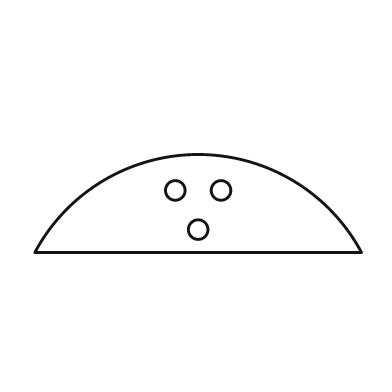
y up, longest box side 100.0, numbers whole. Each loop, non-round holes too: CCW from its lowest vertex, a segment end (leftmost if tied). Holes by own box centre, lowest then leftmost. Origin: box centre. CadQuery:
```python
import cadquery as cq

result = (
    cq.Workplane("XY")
    .moveTo(-50.0, -15.0)
    .lineTo(50.0, -15.0)
    .threePointArc((0.0, 15.0), (-50.0, -15.0))
    .close()
    .moveTo(0.0, -8.0)
    .circle(3.0)
    .moveTo(-7.0, 4.0)
    .circle(3.0)
    .moveTo(7.0, 4.0)
    .circle(3.0)
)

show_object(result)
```